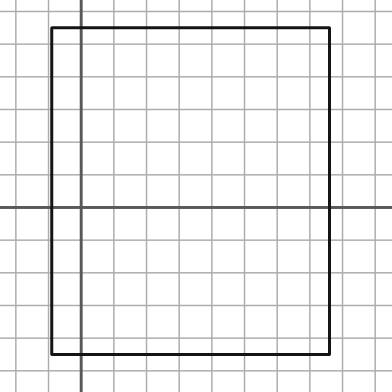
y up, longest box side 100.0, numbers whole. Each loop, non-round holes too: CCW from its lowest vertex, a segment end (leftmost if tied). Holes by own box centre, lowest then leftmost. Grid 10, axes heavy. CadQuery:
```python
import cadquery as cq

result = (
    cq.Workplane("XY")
    .moveTo(-9.0, -45.0)
    .lineTo(76.0, -45.0)
    .lineTo(76.0, 55.0)
    .lineTo(-9.0, 55.0)
    .close()
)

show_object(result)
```